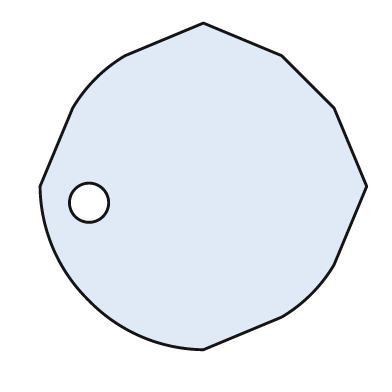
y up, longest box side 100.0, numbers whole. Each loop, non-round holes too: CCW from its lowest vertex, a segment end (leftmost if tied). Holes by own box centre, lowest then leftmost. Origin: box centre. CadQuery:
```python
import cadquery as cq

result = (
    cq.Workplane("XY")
    .moveTo(0.0, -50.0)
    .lineTo(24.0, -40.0)
    .threePointArc((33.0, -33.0), (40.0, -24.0))
    .lineTo(50.0, 0.0)
    .lineTo(40.0, 24.0)
    .lineTo(24.0, 40.0)
    .lineTo(0.0, 50.0)
    .lineTo(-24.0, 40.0)
    .threePointArc((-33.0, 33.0), (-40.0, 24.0))
    .lineTo(-50.0, 0.0)
    .threePointArc((-46.0, -19.0), (-35.0, -35.0))
    .threePointArc((-19.0, -46.0), (0.0, -50.0))
    .close()
    .moveTo(-35.0, -5.0)
    .circle(6.0)
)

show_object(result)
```